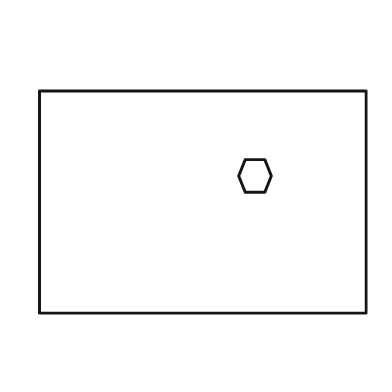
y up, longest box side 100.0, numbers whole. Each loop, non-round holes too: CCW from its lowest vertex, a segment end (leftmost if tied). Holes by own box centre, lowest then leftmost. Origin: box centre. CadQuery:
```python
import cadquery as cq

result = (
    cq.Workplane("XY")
    .moveTo(-50.0, -34.0)
    .lineTo(50.0, -34.0)
    .lineTo(50.0, 34.0)
    .lineTo(-50.0, 34.0)
    .close()
    .moveTo(13.0, 3.0)
    .lineTo(19.0, 3.0)
    .lineTo(21.0, 8.0)
    .lineTo(19.0, 13.0)
    .lineTo(13.0, 13.0)
    .lineTo(11.0, 8.0)
    .close()
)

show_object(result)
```